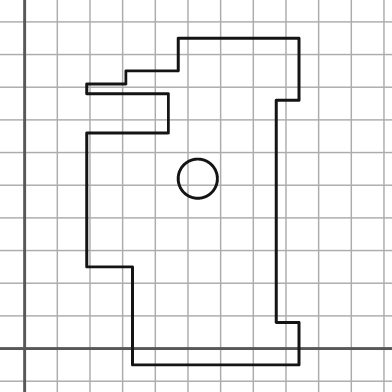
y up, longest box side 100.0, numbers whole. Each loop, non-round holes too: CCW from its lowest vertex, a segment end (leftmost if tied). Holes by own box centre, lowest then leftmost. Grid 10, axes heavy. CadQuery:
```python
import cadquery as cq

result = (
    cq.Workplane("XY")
    .moveTo(33.0, -5.0)
    .lineTo(84.0, -5.0)
    .lineTo(84.0, 8.0)
    .lineTo(77.0, 8.0)
    .lineTo(77.0, 76.0)
    .lineTo(84.0, 76.0)
    .lineTo(84.0, 95.0)
    .lineTo(47.0, 95.0)
    .lineTo(47.0, 85.0)
    .lineTo(31.0, 85.0)
    .lineTo(31.0, 81.0)
    .lineTo(19.0, 81.0)
    .lineTo(19.0, 78.0)
    .lineTo(44.0, 78.0)
    .lineTo(44.0, 66.0)
    .lineTo(19.0, 66.0)
    .lineTo(19.0, 25.0)
    .lineTo(33.0, 25.0)
    .close()
    .moveTo(53.0, 52.0)
    .circle(6.0)
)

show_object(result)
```